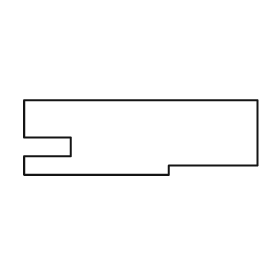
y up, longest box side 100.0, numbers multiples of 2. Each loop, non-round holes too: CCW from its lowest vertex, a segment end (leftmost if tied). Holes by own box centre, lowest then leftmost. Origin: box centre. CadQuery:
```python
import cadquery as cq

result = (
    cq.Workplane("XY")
    .moveTo(-50.0, -16.0)
    .lineTo(12.0, -16.0)
    .lineTo(12.0, -12.0)
    .lineTo(50.0, -12.0)
    .lineTo(50.0, 16.0)
    .lineTo(-50.0, 16.0)
    .lineTo(-50.0, 0.0)
    .lineTo(-30.0, 0.0)
    .lineTo(-30.0, -8.0)
    .lineTo(-50.0, -8.0)
    .close()
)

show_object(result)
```